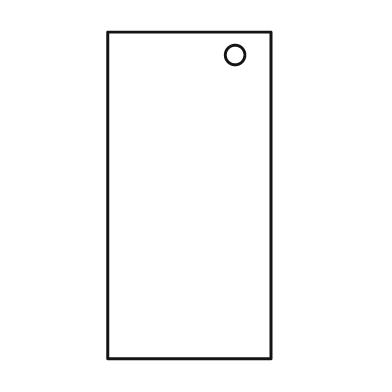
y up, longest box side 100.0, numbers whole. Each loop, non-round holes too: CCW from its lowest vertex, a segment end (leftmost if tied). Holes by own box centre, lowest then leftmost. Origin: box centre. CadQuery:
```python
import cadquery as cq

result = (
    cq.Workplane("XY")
    .moveTo(-25.0, -50.0)
    .lineTo(25.0, -50.0)
    .lineTo(25.0, 50.0)
    .lineTo(-25.0, 50.0)
    .close()
    .moveTo(14.0, 43.0)
    .circle(3.0)
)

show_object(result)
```